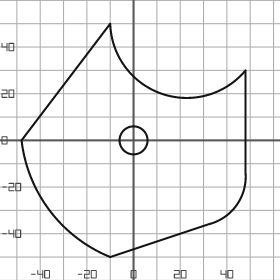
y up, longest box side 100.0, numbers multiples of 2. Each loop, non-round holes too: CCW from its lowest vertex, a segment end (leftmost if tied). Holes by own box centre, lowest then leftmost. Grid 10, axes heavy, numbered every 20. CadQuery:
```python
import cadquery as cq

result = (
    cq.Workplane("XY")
    .moveTo(-10.0, -50.0)
    .lineTo(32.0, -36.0)
    .threePointArc((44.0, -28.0), (48.0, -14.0))
    .lineTo(48.0, 30.0)
    .threePointArc((12.0, 20.0), (-10.0, 50.0))
    .lineTo(-48.0, 0.0)
    .threePointArc((-36.0, -30.0), (-10.0, -50.0))
    .close()
    .moveTo(0.0, 0.0)
    .circle(6.0)
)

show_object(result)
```